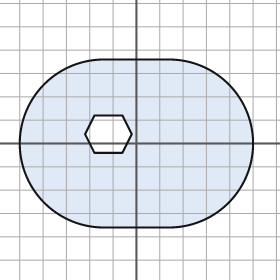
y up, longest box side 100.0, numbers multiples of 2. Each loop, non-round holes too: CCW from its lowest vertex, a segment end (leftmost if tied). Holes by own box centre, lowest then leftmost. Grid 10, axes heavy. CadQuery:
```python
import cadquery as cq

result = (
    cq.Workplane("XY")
    .moveTo(-14.0, -36.0)
    .lineTo(14.0, -36.0)
    .threePointArc((50.0, 0.0), (14.0, 36.0))
    .lineTo(-14.0, 36.0)
    .threePointArc((-50.0, 0.0), (-14.0, -36.0))
    .close()
    .moveTo(-18.0, -4.0)
    .lineTo(-6.0, -4.0)
    .lineTo(-2.0, 4.0)
    .lineTo(-6.0, 12.0)
    .lineTo(-18.0, 12.0)
    .lineTo(-22.0, 4.0)
    .close()
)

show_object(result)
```